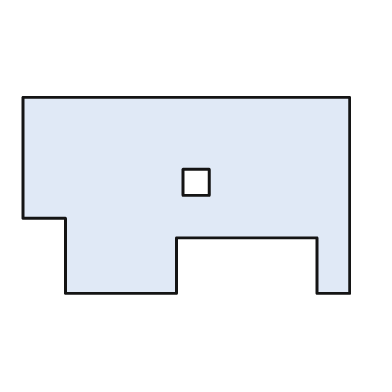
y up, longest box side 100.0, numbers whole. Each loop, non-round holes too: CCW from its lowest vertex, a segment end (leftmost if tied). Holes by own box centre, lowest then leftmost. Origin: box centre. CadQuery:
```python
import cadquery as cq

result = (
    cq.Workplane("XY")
    .moveTo(-37.0, -30.0)
    .lineTo(-3.0, -30.0)
    .lineTo(-3.0, -13.0)
    .lineTo(40.0, -13.0)
    .lineTo(40.0, -30.0)
    .lineTo(50.0, -30.0)
    .lineTo(50.0, 30.0)
    .lineTo(-50.0, 30.0)
    .lineTo(-50.0, -7.0)
    .lineTo(-37.0, -7.0)
    .close()
    .moveTo(-1.0, 0.0)
    .lineTo(7.0, 0.0)
    .lineTo(7.0, 8.0)
    .lineTo(-1.0, 8.0)
    .close()
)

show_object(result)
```